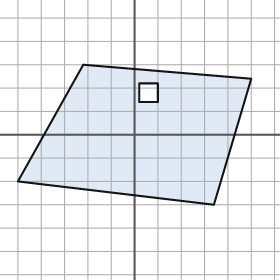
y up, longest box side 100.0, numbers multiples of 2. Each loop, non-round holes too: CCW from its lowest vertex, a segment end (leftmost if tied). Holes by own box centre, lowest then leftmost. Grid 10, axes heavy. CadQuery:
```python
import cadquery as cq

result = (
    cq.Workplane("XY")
    .moveTo(34.0, -30.0)
    .lineTo(50.0, 24.0)
    .lineTo(-22.0, 30.0)
    .lineTo(-50.0, -20.0)
    .close()
    .moveTo(2.0, 14.0)
    .lineTo(10.0, 14.0)
    .lineTo(10.0, 22.0)
    .lineTo(2.0, 22.0)
    .close()
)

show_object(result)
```